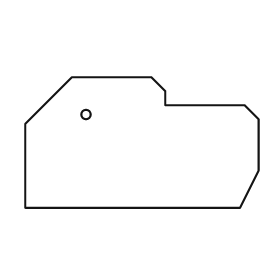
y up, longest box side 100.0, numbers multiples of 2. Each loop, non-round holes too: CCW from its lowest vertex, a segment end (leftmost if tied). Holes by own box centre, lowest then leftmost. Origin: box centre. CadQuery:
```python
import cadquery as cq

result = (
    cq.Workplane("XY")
    .moveTo(-50.0, -28.0)
    .lineTo(42.0, -28.0)
    .lineTo(50.0, -12.0)
    .lineTo(50.0, 10.0)
    .lineTo(44.0, 16.0)
    .lineTo(10.0, 16.0)
    .lineTo(10.0, 22.0)
    .lineTo(4.0, 28.0)
    .lineTo(-30.0, 28.0)
    .lineTo(-50.0, 8.0)
    .close()
    .moveTo(-24.0, 12.0)
    .circle(2.0)
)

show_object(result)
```